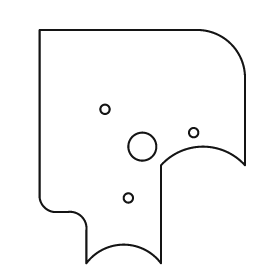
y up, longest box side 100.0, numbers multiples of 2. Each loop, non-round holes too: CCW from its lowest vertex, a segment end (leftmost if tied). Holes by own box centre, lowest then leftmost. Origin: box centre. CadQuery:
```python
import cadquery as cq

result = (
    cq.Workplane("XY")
    .moveTo(-24.0, -50.0)
    .threePointArc((-8.0, -42.0), (8.0, -50.0))
    .lineTo(8.0, -8.0)
    .threePointArc((26.0, 0.0), (44.0, -8.0))
    .lineTo(44.0, 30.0)
    .threePointArc((38.0, 44.0), (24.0, 50.0))
    .lineTo(-44.0, 50.0)
    .lineTo(-44.0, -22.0)
    .threePointArc((-42.0, -26.0), (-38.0, -28.0))
    .lineTo(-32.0, -28.0)
    .threePointArc((-26.0, -30.0), (-24.0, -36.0))
    .close()
    .moveTo(-6.0, -22.0)
    .circle(2.0)
    .moveTo(0.0, 0.0)
    .circle(6.0)
    .moveTo(22.0, 6.0)
    .circle(2.0)
    .moveTo(-16.0, 16.0)
    .circle(2.0)
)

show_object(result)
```